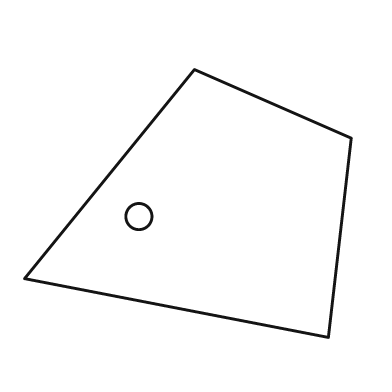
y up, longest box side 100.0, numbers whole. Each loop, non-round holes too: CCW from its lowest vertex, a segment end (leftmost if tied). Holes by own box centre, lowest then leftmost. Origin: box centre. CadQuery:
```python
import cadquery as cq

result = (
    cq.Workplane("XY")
    .moveTo(43.0, -41.0)
    .lineTo(50.0, 20.0)
    .lineTo(2.0, 41.0)
    .lineTo(-50.0, -23.0)
    .close()
    .moveTo(-15.0, -4.0)
    .circle(4.0)
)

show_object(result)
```